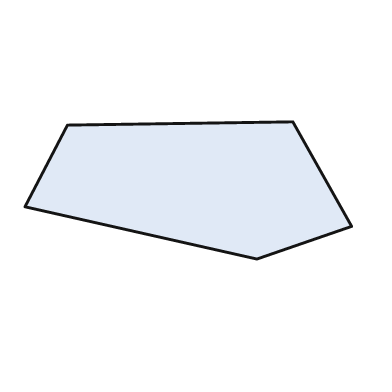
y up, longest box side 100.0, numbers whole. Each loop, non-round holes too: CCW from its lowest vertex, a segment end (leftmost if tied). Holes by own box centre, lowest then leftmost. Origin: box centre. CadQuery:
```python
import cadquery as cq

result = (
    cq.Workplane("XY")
    .moveTo(21.0, -21.0)
    .lineTo(50.0, -11.0)
    .lineTo(32.0, 21.0)
    .lineTo(-37.0, 20.0)
    .lineTo(-50.0, -5.0)
    .close()
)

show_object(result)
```